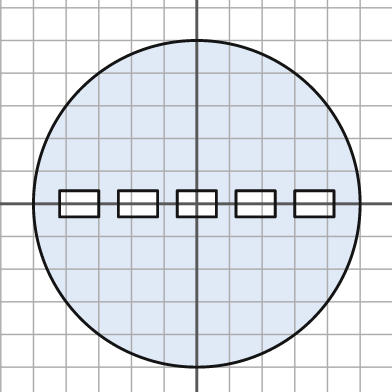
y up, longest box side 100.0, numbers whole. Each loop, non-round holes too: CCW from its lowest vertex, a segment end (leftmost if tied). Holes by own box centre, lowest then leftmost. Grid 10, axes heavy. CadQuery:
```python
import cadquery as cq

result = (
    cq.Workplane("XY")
    .moveTo(0.0, 0.0)
    .circle(50.0)
    .moveTo(-42.0, -4.0)
    .lineTo(-30.0, -4.0)
    .lineTo(-30.0, 4.0)
    .lineTo(-42.0, 4.0)
    .close()
    .moveTo(-24.0, -4.0)
    .lineTo(-12.0, -4.0)
    .lineTo(-12.0, 4.0)
    .lineTo(-24.0, 4.0)
    .close()
    .moveTo(-6.0, -4.0)
    .lineTo(6.0, -4.0)
    .lineTo(6.0, 4.0)
    .lineTo(-6.0, 4.0)
    .close()
    .moveTo(12.0, -4.0)
    .lineTo(24.0, -4.0)
    .lineTo(24.0, 4.0)
    .lineTo(12.0, 4.0)
    .close()
    .moveTo(30.0, -4.0)
    .lineTo(42.0, -4.0)
    .lineTo(42.0, 4.0)
    .lineTo(30.0, 4.0)
    .close()
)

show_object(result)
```